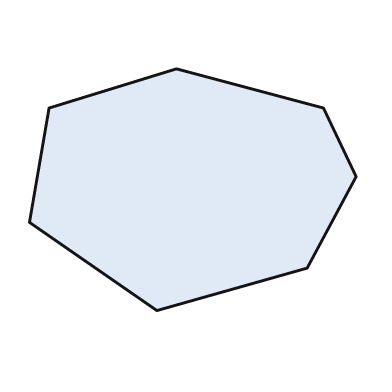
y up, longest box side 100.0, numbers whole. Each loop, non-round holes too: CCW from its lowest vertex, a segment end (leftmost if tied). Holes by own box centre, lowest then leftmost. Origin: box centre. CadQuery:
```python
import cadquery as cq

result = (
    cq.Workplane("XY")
    .moveTo(-11.0, -37.0)
    .lineTo(35.0, -24.0)
    .lineTo(50.0, 4.0)
    .lineTo(40.0, 25.0)
    .lineTo(-5.0, 37.0)
    .lineTo(-44.0, 25.0)
    .lineTo(-50.0, -10.0)
    .close()
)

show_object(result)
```